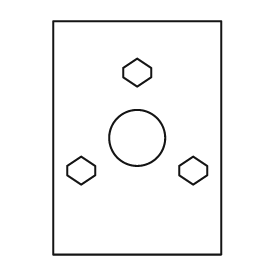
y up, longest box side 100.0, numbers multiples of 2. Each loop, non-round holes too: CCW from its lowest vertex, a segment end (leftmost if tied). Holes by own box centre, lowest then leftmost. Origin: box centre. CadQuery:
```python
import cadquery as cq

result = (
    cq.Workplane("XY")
    .moveTo(-36.0, -50.0)
    .lineTo(36.0, -50.0)
    .lineTo(36.0, 50.0)
    .lineTo(-36.0, 50.0)
    .close()
    .moveTo(-24.0, -20.0)
    .lineTo(-18.0, -16.0)
    .lineTo(-18.0, -12.0)
    .lineTo(-24.0, -8.0)
    .lineTo(-30.0, -12.0)
    .lineTo(-30.0, -16.0)
    .close()
    .moveTo(24.0, -20.0)
    .lineTo(30.0, -16.0)
    .lineTo(30.0, -12.0)
    .lineTo(24.0, -8.0)
    .lineTo(18.0, -12.0)
    .lineTo(18.0, -16.0)
    .close()
    .moveTo(0.0, 0.0)
    .circle(12.0)
    .moveTo(0.0, 22.0)
    .lineTo(6.0, 26.0)
    .lineTo(6.0, 30.0)
    .lineTo(0.0, 34.0)
    .lineTo(-6.0, 30.0)
    .lineTo(-6.0, 26.0)
    .close()
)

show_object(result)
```